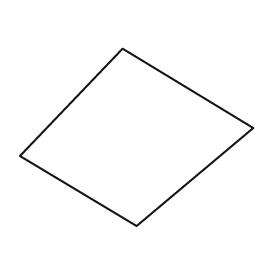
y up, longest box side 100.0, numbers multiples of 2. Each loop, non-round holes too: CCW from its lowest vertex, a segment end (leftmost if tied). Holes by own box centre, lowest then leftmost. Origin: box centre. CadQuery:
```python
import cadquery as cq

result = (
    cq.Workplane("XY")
    .moveTo(0.0, -38.0)
    .lineTo(50.0, 4.0)
    .lineTo(-6.0, 38.0)
    .lineTo(-50.0, -8.0)
    .close()
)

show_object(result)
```